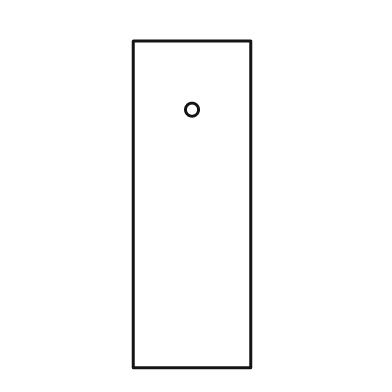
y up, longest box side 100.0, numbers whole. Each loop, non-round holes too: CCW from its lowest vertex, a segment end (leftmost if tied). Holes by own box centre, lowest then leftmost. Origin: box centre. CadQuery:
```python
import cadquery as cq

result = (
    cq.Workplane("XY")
    .moveTo(-18.0, -50.0)
    .lineTo(18.0, -50.0)
    .lineTo(18.0, 50.0)
    .lineTo(-18.0, 50.0)
    .close()
    .moveTo(0.0, 29.0)
    .circle(2.0)
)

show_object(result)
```